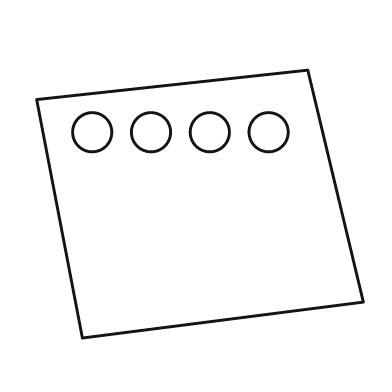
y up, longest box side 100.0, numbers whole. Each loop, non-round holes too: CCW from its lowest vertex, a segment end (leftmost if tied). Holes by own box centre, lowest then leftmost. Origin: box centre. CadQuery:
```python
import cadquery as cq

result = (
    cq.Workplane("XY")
    .moveTo(-36.0, -41.0)
    .lineTo(50.0, -30.0)
    .lineTo(33.0, 41.0)
    .lineTo(-50.0, 32.0)
    .close()
    .moveTo(-33.0, 22.0)
    .circle(6.0)
    .moveTo(-15.0, 22.0)
    .circle(6.0)
    .moveTo(3.0, 22.0)
    .circle(6.0)
    .moveTo(21.0, 22.0)
    .circle(6.0)
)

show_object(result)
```